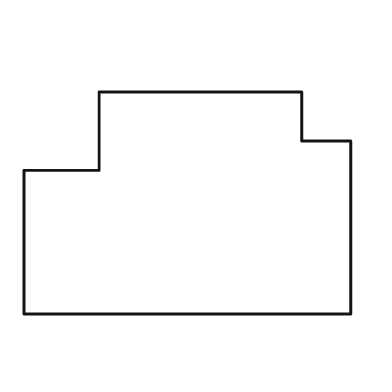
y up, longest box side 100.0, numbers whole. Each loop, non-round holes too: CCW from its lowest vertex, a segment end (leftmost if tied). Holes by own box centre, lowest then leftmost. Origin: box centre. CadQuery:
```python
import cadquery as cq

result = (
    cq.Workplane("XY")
    .moveTo(-50.0, -34.0)
    .lineTo(50.0, -34.0)
    .lineTo(50.0, 19.0)
    .lineTo(35.0, 19.0)
    .lineTo(35.0, 34.0)
    .lineTo(-27.0, 34.0)
    .lineTo(-27.0, 10.0)
    .lineTo(-50.0, 10.0)
    .close()
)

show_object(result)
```